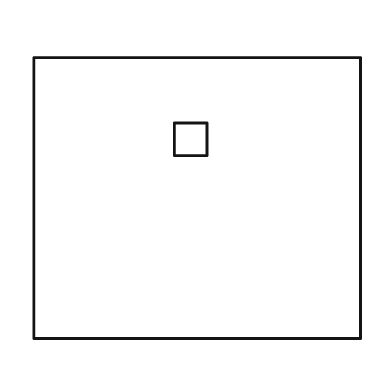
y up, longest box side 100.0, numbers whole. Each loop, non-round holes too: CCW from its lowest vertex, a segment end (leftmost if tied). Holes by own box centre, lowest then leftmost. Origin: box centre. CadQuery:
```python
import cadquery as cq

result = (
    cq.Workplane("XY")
    .moveTo(-50.0, -43.0)
    .lineTo(50.0, -43.0)
    .lineTo(50.0, 43.0)
    .lineTo(-50.0, 43.0)
    .close()
    .moveTo(-7.0, 13.0)
    .lineTo(3.0, 13.0)
    .lineTo(3.0, 23.0)
    .lineTo(-7.0, 23.0)
    .close()
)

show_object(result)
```